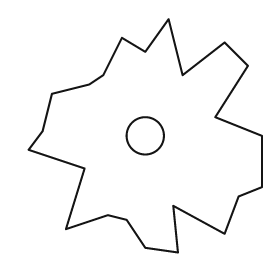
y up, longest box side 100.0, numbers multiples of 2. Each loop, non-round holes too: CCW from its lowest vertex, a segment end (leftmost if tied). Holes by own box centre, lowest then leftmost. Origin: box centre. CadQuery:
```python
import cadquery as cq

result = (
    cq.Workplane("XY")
    .moveTo(14.0, -50.0)
    .lineTo(12.0, -30.0)
    .lineTo(34.0, -42.0)
    .lineTo(40.0, -26.0)
    .lineTo(50.0, -22.0)
    .lineTo(50.0, 0.0)
    .lineTo(30.0, 8.0)
    .lineTo(44.0, 30.0)
    .lineTo(34.0, 40.0)
    .lineTo(16.0, 26.0)
    .lineTo(10.0, 50.0)
    .lineTo(0.0, 36.0)
    .lineTo(-10.0, 42.0)
    .lineTo(-18.0, 26.0)
    .lineTo(-24.0, 22.0)
    .lineTo(-40.0, 18.0)
    .lineTo(-44.0, 2.0)
    .lineTo(-50.0, -6.0)
    .lineTo(-26.0, -14.0)
    .lineTo(-34.0, -40.0)
    .lineTo(-16.0, -34.0)
    .lineTo(-8.0, -36.0)
    .lineTo(0.0, -48.0)
    .close()
    .moveTo(0.0, 0.0)
    .circle(8.0)
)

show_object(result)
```